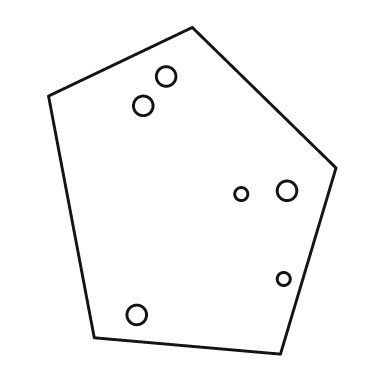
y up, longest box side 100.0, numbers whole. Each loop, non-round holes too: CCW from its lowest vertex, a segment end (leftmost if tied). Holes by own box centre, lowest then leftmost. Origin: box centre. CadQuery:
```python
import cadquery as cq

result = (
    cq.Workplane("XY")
    .moveTo(27.0, -50.0)
    .lineTo(44.0, 7.0)
    .lineTo(0.0, 50.0)
    .lineTo(-44.0, 29.0)
    .lineTo(-30.0, -45.0)
    .close()
    .moveTo(-17.0, -38.0)
    .circle(3.0)
    .moveTo(28.0, -27.0)
    .circle(2.0)
    .moveTo(15.0, -1.0)
    .circle(2.0)
    .moveTo(29.0, 0.0)
    .circle(3.0)
    .moveTo(-15.0, 26.0)
    .circle(3.0)
    .moveTo(-8.0, 35.0)
    .circle(3.0)
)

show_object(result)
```